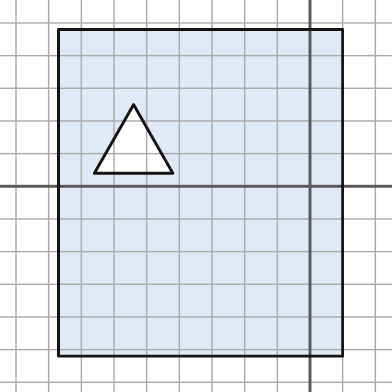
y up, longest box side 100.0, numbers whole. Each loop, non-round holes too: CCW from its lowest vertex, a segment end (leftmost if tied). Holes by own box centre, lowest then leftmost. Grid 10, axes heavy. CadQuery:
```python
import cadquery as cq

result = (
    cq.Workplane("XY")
    .moveTo(-77.0, -52.0)
    .lineTo(10.0, -52.0)
    .lineTo(10.0, 48.0)
    .lineTo(-77.0, 48.0)
    .close()
    .moveTo(-66.0, 4.0)
    .lineTo(-42.0, 4.0)
    .lineTo(-54.0, 25.0)
    .close()
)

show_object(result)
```